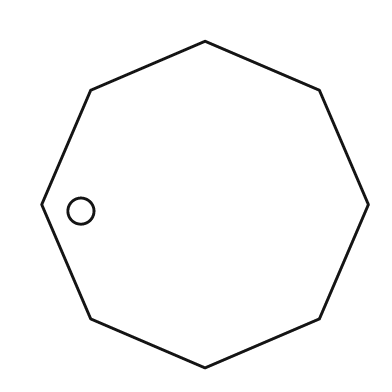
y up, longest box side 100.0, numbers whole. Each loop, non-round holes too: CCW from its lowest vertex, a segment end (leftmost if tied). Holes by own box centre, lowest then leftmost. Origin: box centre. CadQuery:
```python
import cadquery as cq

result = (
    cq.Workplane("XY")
    .moveTo(0.0, -50.0)
    .lineTo(35.0, -35.0)
    .lineTo(50.0, 0.0)
    .lineTo(35.0, 35.0)
    .lineTo(0.0, 50.0)
    .lineTo(-35.0, 35.0)
    .lineTo(-50.0, 0.0)
    .lineTo(-35.0, -35.0)
    .close()
    .moveTo(-38.0, -2.0)
    .circle(4.0)
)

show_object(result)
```